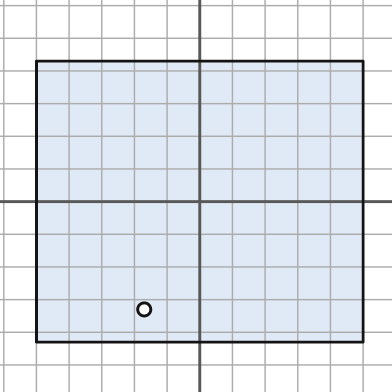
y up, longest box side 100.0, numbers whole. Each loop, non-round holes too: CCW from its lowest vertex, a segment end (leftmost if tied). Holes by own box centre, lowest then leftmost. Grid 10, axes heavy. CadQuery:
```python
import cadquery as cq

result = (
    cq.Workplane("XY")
    .moveTo(-50.0, -43.0)
    .lineTo(50.0, -43.0)
    .lineTo(50.0, 43.0)
    .lineTo(-50.0, 43.0)
    .close()
    .moveTo(-17.0, -33.0)
    .circle(2.0)
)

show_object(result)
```